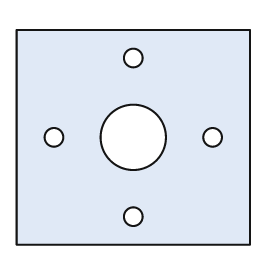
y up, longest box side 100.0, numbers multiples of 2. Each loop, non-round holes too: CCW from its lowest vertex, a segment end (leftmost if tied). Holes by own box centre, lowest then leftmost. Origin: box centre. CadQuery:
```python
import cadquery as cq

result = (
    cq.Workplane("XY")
    .moveTo(-50.0, -46.0)
    .lineTo(50.0, -46.0)
    .lineTo(50.0, 46.0)
    .lineTo(-50.0, 46.0)
    .close()
    .moveTo(0.0, -34.0)
    .circle(4.0)
    .moveTo(-34.0, 0.0)
    .circle(4.0)
    .moveTo(0.0, 0.0)
    .circle(14.0)
    .moveTo(34.0, 0.0)
    .circle(4.0)
    .moveTo(0.0, 34.0)
    .circle(4.0)
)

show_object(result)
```